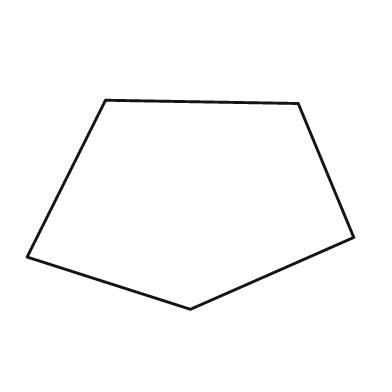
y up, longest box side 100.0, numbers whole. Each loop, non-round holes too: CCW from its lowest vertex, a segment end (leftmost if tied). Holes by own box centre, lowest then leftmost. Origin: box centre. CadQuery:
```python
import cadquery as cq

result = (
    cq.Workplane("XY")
    .moveTo(0.0, -32.0)
    .lineTo(50.0, -10.0)
    .lineTo(33.0, 31.0)
    .lineTo(-26.0, 32.0)
    .lineTo(-50.0, -16.0)
    .close()
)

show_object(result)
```